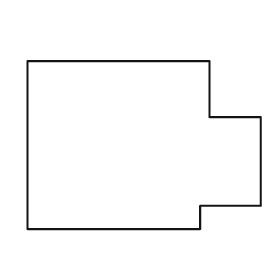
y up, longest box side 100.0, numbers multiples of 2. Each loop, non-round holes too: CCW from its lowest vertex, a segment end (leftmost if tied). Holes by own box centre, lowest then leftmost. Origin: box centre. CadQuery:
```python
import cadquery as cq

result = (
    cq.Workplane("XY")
    .moveTo(-50.0, -36.0)
    .lineTo(24.0, -36.0)
    .lineTo(24.0, -26.0)
    .lineTo(50.0, -26.0)
    .lineTo(50.0, 12.0)
    .lineTo(28.0, 12.0)
    .lineTo(28.0, 36.0)
    .lineTo(-50.0, 36.0)
    .close()
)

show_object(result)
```